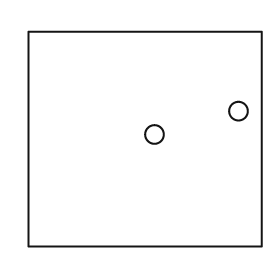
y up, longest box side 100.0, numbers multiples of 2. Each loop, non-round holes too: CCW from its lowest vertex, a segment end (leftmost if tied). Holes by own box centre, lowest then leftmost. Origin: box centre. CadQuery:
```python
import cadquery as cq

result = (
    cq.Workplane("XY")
    .moveTo(-50.0, -46.0)
    .lineTo(50.0, -46.0)
    .lineTo(50.0, 46.0)
    .lineTo(-50.0, 46.0)
    .close()
    .moveTo(4.0, 2.0)
    .circle(4.0)
    .moveTo(40.0, 12.0)
    .circle(4.0)
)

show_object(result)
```